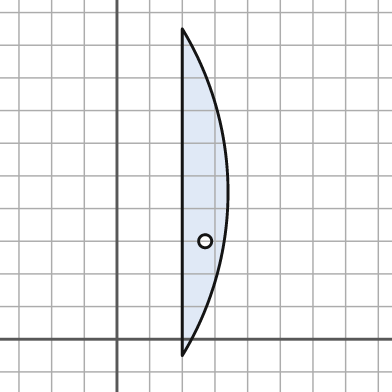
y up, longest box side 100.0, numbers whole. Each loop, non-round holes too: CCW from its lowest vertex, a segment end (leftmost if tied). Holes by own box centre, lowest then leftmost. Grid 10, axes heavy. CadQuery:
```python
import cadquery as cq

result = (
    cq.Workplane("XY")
    .moveTo(20.0, -5.0)
    .threePointArc((34.0, 45.0), (20.0, 95.0))
    .close()
    .moveTo(27.0, 30.0)
    .circle(2.0)
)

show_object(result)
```